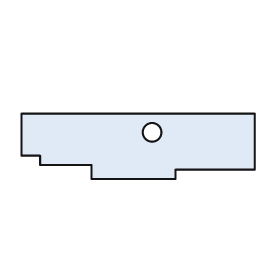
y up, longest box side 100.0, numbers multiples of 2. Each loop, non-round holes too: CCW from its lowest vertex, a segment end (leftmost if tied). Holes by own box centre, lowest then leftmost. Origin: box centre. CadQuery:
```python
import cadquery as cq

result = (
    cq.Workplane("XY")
    .moveTo(-20.0, -14.0)
    .lineTo(16.0, -14.0)
    .lineTo(16.0, -10.0)
    .lineTo(50.0, -10.0)
    .lineTo(50.0, 14.0)
    .lineTo(-50.0, 14.0)
    .lineTo(-50.0, -4.0)
    .lineTo(-42.0, -4.0)
    .lineTo(-42.0, -8.0)
    .lineTo(-20.0, -8.0)
    .close()
    .moveTo(6.0, 6.0)
    .circle(4.0)
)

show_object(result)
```